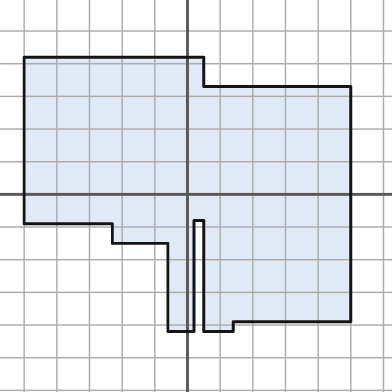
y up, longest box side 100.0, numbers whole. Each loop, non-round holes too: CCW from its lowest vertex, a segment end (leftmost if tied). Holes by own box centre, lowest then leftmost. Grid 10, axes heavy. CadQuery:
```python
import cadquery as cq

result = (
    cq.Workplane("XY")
    .moveTo(-6.0, -42.0)
    .lineTo(2.0, -42.0)
    .lineTo(2.0, -8.0)
    .lineTo(5.0, -8.0)
    .lineTo(5.0, -42.0)
    .lineTo(14.0, -42.0)
    .lineTo(14.0, -39.0)
    .lineTo(50.0, -39.0)
    .lineTo(50.0, 33.0)
    .lineTo(5.0, 33.0)
    .lineTo(5.0, 42.0)
    .lineTo(-50.0, 42.0)
    .lineTo(-50.0, -9.0)
    .lineTo(-23.0, -9.0)
    .lineTo(-23.0, -15.0)
    .lineTo(-6.0, -15.0)
    .close()
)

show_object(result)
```